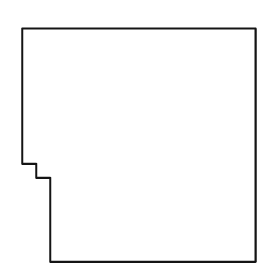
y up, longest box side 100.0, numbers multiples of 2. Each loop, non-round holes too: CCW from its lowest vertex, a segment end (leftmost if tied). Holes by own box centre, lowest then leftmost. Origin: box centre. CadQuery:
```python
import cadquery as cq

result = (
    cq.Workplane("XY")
    .moveTo(-38.0, -50.0)
    .lineTo(50.0, -50.0)
    .lineTo(50.0, 50.0)
    .lineTo(-50.0, 50.0)
    .lineTo(-50.0, -8.0)
    .lineTo(-44.0, -8.0)
    .lineTo(-44.0, -14.0)
    .lineTo(-38.0, -14.0)
    .close()
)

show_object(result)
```